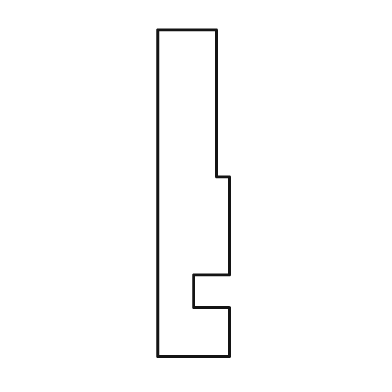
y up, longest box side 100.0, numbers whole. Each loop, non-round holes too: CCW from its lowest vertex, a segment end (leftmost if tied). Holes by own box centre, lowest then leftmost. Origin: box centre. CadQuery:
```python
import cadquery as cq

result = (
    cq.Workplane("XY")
    .moveTo(-11.0, -50.0)
    .lineTo(11.0, -50.0)
    .lineTo(11.0, -35.0)
    .lineTo(0.0, -35.0)
    .lineTo(0.0, -25.0)
    .lineTo(11.0, -25.0)
    .lineTo(11.0, 5.0)
    .lineTo(7.0, 5.0)
    .lineTo(7.0, 50.0)
    .lineTo(-11.0, 50.0)
    .close()
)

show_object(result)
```